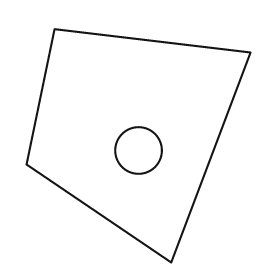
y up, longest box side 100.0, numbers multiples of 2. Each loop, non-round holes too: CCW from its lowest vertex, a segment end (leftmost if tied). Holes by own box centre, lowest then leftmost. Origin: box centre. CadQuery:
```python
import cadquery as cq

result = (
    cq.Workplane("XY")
    .moveTo(14.0, -50.0)
    .lineTo(48.0, 40.0)
    .lineTo(-36.0, 50.0)
    .lineTo(-48.0, -8.0)
    .close()
    .moveTo(0.0, -2.0)
    .circle(10.0)
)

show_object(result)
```